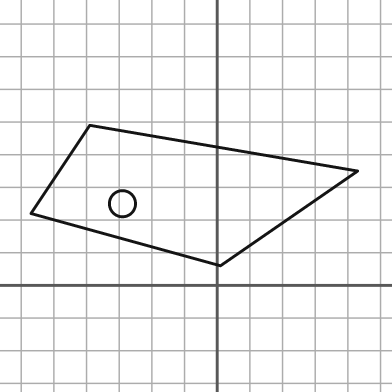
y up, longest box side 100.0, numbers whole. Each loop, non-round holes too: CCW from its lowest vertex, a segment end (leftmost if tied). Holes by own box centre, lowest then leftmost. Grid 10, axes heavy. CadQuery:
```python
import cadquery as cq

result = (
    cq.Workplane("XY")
    .moveTo(1.0, 6.0)
    .lineTo(43.0, 35.0)
    .lineTo(-39.0, 49.0)
    .lineTo(-57.0, 22.0)
    .close()
    .moveTo(-29.0, 25.0)
    .circle(4.0)
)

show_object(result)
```